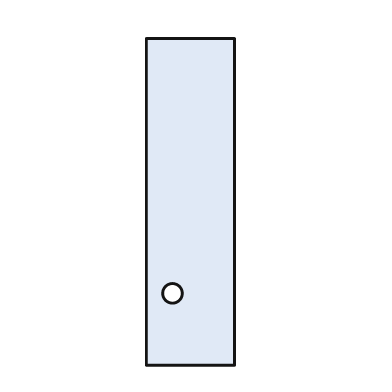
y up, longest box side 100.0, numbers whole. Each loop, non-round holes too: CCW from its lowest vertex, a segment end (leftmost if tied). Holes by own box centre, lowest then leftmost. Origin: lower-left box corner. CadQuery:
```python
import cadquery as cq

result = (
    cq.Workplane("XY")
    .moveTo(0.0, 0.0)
    .lineTo(27.0, 0.0)
    .lineTo(27.0, 100.0)
    .lineTo(0.0, 100.0)
    .close()
    .moveTo(8.0, 22.0)
    .circle(3.0)
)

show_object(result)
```